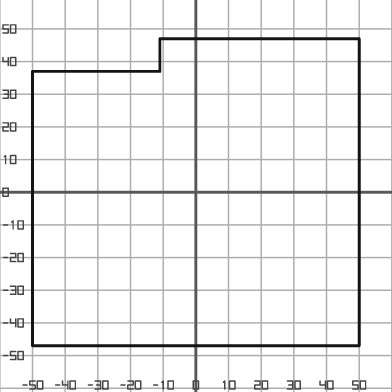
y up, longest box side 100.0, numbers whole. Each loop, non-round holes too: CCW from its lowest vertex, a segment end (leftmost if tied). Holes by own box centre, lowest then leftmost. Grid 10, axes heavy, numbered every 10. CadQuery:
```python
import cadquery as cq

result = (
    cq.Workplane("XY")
    .moveTo(-50.0, -47.0)
    .lineTo(50.0, -47.0)
    .lineTo(50.0, 47.0)
    .lineTo(-11.0, 47.0)
    .lineTo(-11.0, 37.0)
    .lineTo(-50.0, 37.0)
    .close()
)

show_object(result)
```